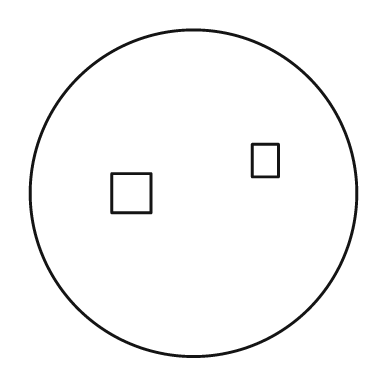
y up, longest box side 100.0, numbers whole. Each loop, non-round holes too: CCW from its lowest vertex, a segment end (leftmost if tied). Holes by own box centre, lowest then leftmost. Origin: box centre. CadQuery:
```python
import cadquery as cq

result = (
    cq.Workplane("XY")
    .moveTo(0.0, 0.0)
    .circle(50.0)
    .moveTo(-25.0, -6.0)
    .lineTo(-13.0, -6.0)
    .lineTo(-13.0, 6.0)
    .lineTo(-25.0, 6.0)
    .close()
    .moveTo(18.0, 5.0)
    .lineTo(26.0, 5.0)
    .lineTo(26.0, 15.0)
    .lineTo(18.0, 15.0)
    .close()
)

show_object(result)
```